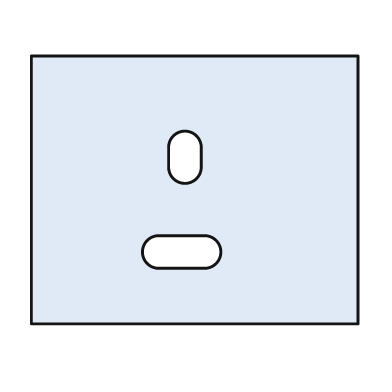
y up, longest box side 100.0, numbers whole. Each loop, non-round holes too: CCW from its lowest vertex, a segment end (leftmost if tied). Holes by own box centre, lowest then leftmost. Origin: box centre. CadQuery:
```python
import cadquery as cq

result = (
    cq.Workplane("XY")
    .moveTo(-50.0, -41.0)
    .lineTo(50.0, -41.0)
    .lineTo(50.0, 41.0)
    .lineTo(-50.0, 41.0)
    .close()
    .moveTo(-11.0, -24.0)
    .lineTo(3.0, -24.0)
    .threePointArc((8.0, -19.0), (3.0, -14.0))
    .lineTo(-11.0, -14.0)
    .threePointArc((-16.0, -19.0), (-11.0, -24.0))
    .close()
    .moveTo(-8.0, 7.0)
    .threePointArc((-3.0, 2.0), (2.0, 7.0))
    .lineTo(2.0, 13.0)
    .threePointArc((-3.0, 18.0), (-8.0, 13.0))
    .close()
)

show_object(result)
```